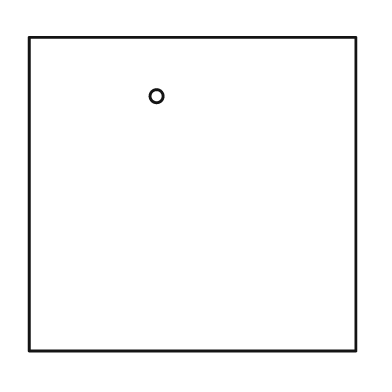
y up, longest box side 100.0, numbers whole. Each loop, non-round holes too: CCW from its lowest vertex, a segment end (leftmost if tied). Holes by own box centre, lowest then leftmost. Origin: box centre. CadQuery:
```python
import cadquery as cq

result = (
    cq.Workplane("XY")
    .moveTo(-50.0, -48.0)
    .lineTo(50.0, -48.0)
    .lineTo(50.0, 48.0)
    .lineTo(-50.0, 48.0)
    .close()
    .moveTo(-11.0, 30.0)
    .circle(2.0)
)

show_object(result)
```